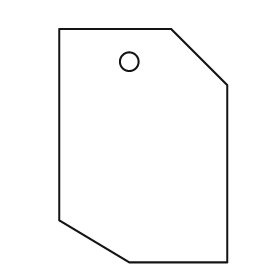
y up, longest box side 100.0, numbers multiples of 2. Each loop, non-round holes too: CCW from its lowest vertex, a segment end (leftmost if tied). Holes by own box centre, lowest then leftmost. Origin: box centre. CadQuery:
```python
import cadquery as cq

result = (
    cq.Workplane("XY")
    .moveTo(-6.0, -50.0)
    .lineTo(36.0, -50.0)
    .lineTo(36.0, 26.0)
    .lineTo(12.0, 50.0)
    .lineTo(-36.0, 50.0)
    .lineTo(-36.0, -32.0)
    .close()
    .moveTo(-6.0, 36.0)
    .circle(4.0)
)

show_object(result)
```